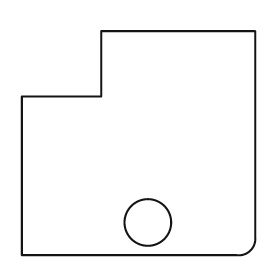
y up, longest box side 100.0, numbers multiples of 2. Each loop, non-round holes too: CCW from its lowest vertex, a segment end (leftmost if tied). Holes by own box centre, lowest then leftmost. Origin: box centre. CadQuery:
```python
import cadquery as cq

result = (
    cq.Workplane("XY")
    .moveTo(-50.0, -48.0)
    .lineTo(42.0, -48.0)
    .threePointArc((48.0, -46.0), (50.0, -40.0))
    .lineTo(50.0, 48.0)
    .lineTo(-16.0, 48.0)
    .lineTo(-16.0, 20.0)
    .lineTo(-50.0, 20.0)
    .close()
    .moveTo(4.0, -34.0)
    .circle(10.0)
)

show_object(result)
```